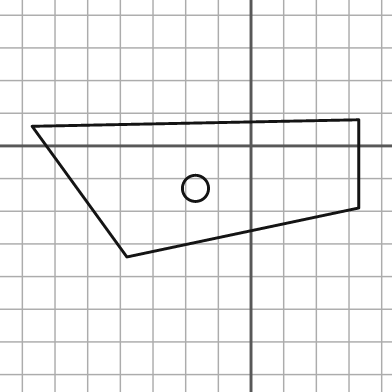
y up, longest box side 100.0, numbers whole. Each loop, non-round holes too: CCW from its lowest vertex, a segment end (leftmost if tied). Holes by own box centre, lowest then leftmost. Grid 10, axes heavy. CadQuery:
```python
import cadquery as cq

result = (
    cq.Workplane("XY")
    .moveTo(-38.0, -34.0)
    .lineTo(33.0, -19.0)
    .lineTo(33.0, 8.0)
    .lineTo(-67.0, 6.0)
    .close()
    .moveTo(-17.0, -13.0)
    .circle(4.0)
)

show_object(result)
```